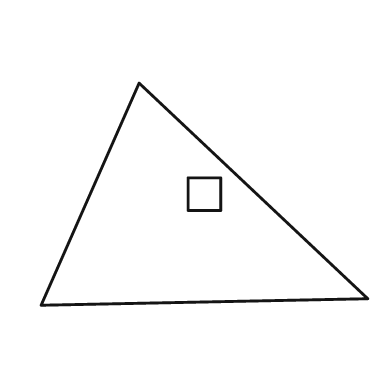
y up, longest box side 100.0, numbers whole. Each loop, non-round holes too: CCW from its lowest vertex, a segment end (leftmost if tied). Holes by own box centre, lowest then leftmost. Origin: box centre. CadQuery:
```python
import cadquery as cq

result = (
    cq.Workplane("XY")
    .moveTo(-50.0, -34.0)
    .lineTo(50.0, -32.0)
    .lineTo(-20.0, 34.0)
    .close()
    .moveTo(-5.0, -5.0)
    .lineTo(5.0, -5.0)
    .lineTo(5.0, 5.0)
    .lineTo(-5.0, 5.0)
    .close()
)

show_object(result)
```